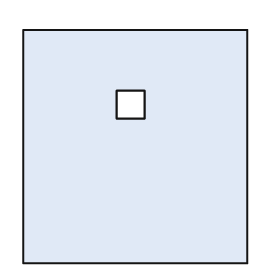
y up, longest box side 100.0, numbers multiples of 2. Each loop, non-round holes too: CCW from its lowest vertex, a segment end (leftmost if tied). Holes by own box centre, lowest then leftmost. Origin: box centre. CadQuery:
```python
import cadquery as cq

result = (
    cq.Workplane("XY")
    .moveTo(-48.0, -50.0)
    .lineTo(48.0, -50.0)
    .lineTo(48.0, 50.0)
    .lineTo(-48.0, 50.0)
    .close()
    .moveTo(-8.0, 12.0)
    .lineTo(4.0, 12.0)
    .lineTo(4.0, 24.0)
    .lineTo(-8.0, 24.0)
    .close()
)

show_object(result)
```